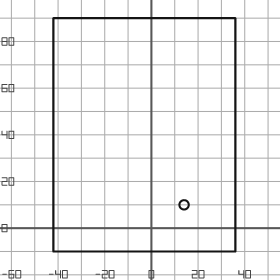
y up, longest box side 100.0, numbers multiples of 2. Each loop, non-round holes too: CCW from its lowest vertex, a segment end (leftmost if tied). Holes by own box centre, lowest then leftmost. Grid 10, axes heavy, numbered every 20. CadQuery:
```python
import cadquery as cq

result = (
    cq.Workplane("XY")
    .moveTo(-42.0, -10.0)
    .lineTo(36.0, -10.0)
    .lineTo(36.0, 90.0)
    .lineTo(-42.0, 90.0)
    .close()
    .moveTo(14.0, 10.0)
    .circle(2.0)
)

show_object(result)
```